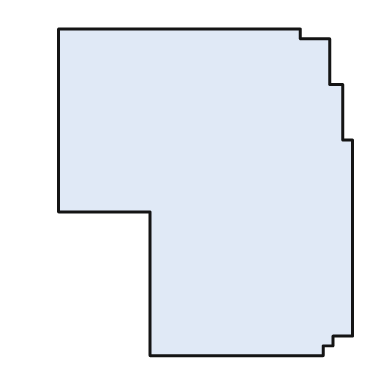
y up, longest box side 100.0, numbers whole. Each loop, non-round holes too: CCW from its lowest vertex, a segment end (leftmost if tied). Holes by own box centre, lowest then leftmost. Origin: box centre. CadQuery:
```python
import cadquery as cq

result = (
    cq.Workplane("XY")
    .moveTo(-17.0, -50.0)
    .lineTo(36.0, -50.0)
    .lineTo(36.0, -47.0)
    .lineTo(39.0, -47.0)
    .lineTo(39.0, -44.0)
    .lineTo(45.0, -44.0)
    .lineTo(45.0, 16.0)
    .lineTo(42.0, 16.0)
    .lineTo(42.0, 33.0)
    .lineTo(38.0, 33.0)
    .lineTo(38.0, 47.0)
    .lineTo(29.0, 47.0)
    .lineTo(29.0, 50.0)
    .lineTo(-45.0, 50.0)
    .lineTo(-45.0, -6.0)
    .lineTo(-17.0, -6.0)
    .close()
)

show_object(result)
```